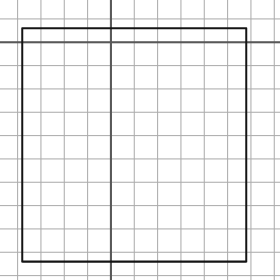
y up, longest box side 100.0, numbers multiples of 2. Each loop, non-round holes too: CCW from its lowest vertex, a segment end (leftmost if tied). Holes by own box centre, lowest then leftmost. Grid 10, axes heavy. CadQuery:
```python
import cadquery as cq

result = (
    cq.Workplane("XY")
    .moveTo(-38.0, -94.0)
    .lineTo(58.0, -94.0)
    .lineTo(58.0, 6.0)
    .lineTo(-38.0, 6.0)
    .close()
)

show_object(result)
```